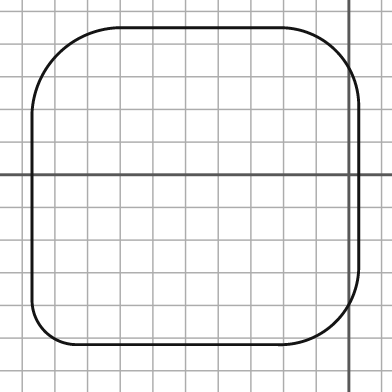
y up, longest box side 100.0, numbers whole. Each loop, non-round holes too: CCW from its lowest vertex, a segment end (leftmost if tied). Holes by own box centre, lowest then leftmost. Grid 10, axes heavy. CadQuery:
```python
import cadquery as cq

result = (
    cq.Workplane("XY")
    .moveTo(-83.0, -52.0)
    .lineTo(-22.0, -52.0)
    .threePointArc((-4.0, -45.0), (3.0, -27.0))
    .lineTo(3.0, 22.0)
    .threePointArc((-4.0, 38.0), (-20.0, 45.0))
    .lineTo(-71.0, 45.0)
    .threePointArc((-89.0, 37.0), (-97.0, 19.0))
    .lineTo(-97.0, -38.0)
    .threePointArc((-93.0, -48.0), (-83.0, -52.0))
    .close()
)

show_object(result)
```